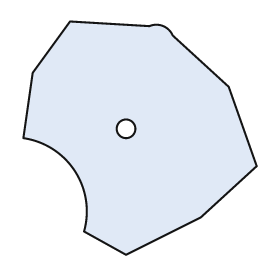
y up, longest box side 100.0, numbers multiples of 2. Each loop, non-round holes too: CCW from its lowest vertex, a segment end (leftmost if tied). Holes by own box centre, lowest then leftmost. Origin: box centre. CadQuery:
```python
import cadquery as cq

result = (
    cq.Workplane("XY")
    .moveTo(-6.0, -50.0)
    .lineTo(26.0, -34.0)
    .lineTo(50.0, -12.0)
    .lineTo(38.0, 22.0)
    .lineTo(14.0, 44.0)
    .threePointArc((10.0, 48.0), (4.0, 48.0))
    .lineTo(-30.0, 50.0)
    .lineTo(-46.0, 28.0)
    .lineTo(-50.0, 0.0)
    .threePointArc((-28.0, -14.0), (-24.0, -40.0))
    .close()
    .moveTo(-6.0, 4.0)
    .circle(4.0)
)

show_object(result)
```